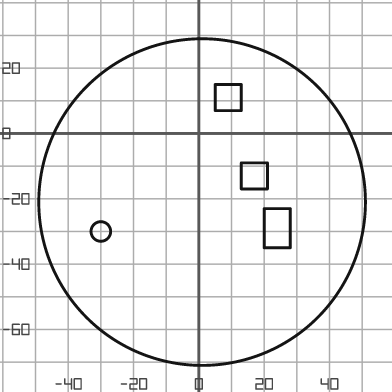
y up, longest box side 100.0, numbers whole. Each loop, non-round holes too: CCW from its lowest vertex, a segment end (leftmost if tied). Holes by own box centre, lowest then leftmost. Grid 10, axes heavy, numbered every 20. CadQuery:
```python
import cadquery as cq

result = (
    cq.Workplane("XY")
    .moveTo(1.0, -21.0)
    .circle(50.0)
    .moveTo(-30.0, -30.0)
    .circle(3.0)
    .moveTo(20.0, -35.0)
    .lineTo(28.0, -35.0)
    .lineTo(28.0, -23.0)
    .lineTo(20.0, -23.0)
    .close()
    .moveTo(13.0, -17.0)
    .lineTo(21.0, -17.0)
    .lineTo(21.0, -9.0)
    .lineTo(13.0, -9.0)
    .close()
    .moveTo(5.0, 7.0)
    .lineTo(13.0, 7.0)
    .lineTo(13.0, 15.0)
    .lineTo(5.0, 15.0)
    .close()
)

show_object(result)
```